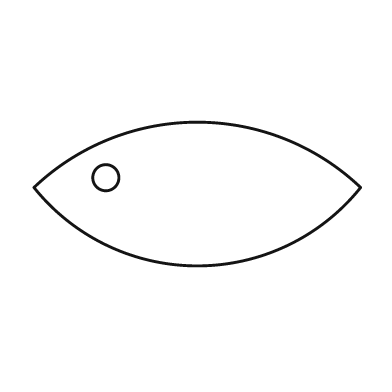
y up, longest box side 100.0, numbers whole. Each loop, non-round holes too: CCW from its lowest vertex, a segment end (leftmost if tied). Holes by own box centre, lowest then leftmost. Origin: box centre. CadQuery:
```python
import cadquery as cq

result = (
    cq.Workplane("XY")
    .moveTo(-50.0, 2.0)
    .threePointArc((0.0, -22.0), (50.0, 2.0))
    .threePointArc((0.0, 22.0), (-50.0, 2.0))
    .close()
    .moveTo(-28.0, 5.0)
    .circle(4.0)
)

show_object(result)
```